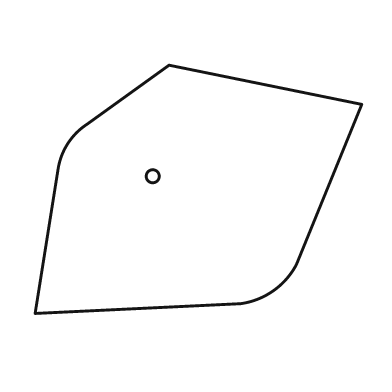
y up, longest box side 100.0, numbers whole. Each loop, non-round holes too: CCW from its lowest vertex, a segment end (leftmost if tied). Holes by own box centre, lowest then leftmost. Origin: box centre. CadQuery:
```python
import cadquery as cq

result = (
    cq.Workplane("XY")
    .moveTo(-50.0, -38.0)
    .lineTo(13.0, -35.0)
    .threePointArc((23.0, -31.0), (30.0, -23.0))
    .lineTo(50.0, 26.0)
    .lineTo(-9.0, 38.0)
    .lineTo(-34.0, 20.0)
    .threePointArc((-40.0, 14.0), (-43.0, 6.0))
    .close()
    .moveTo(-14.0, 4.0)
    .circle(2.0)
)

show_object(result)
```